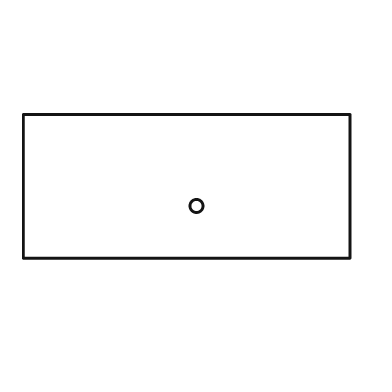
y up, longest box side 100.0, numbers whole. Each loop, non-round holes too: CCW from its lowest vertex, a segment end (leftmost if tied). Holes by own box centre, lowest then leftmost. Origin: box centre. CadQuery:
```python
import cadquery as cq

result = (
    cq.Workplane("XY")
    .moveTo(-50.0, -22.0)
    .lineTo(50.0, -22.0)
    .lineTo(50.0, 22.0)
    .lineTo(-50.0, 22.0)
    .close()
    .moveTo(3.0, -6.0)
    .circle(2.0)
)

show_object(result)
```